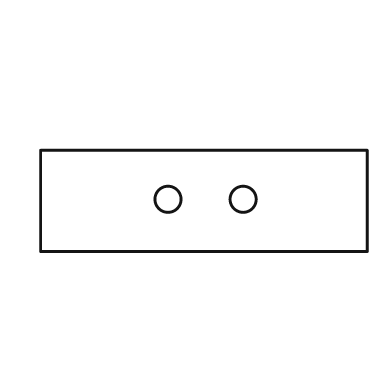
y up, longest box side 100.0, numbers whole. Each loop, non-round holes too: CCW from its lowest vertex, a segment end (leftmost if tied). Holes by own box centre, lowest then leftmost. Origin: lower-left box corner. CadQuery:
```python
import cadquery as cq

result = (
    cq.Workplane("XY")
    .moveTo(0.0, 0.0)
    .lineTo(100.0, 0.0)
    .lineTo(100.0, 31.0)
    .lineTo(0.0, 31.0)
    .close()
    .moveTo(39.0, 16.0)
    .circle(4.0)
    .moveTo(62.0, 16.0)
    .circle(4.0)
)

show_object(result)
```